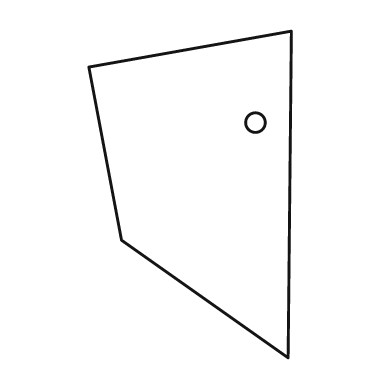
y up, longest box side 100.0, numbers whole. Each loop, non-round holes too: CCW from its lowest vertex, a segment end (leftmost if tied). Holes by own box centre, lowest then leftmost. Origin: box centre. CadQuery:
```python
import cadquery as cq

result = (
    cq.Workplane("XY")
    .moveTo(30.0, -50.0)
    .lineTo(31.0, 50.0)
    .lineTo(-31.0, 39.0)
    .lineTo(-21.0, -14.0)
    .close()
    .moveTo(20.0, 22.0)
    .circle(3.0)
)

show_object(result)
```